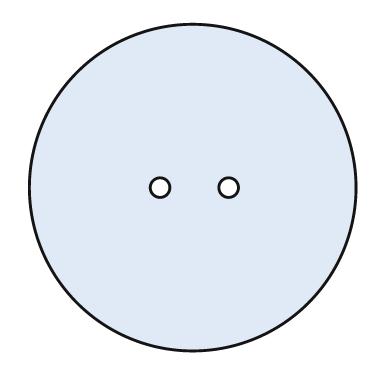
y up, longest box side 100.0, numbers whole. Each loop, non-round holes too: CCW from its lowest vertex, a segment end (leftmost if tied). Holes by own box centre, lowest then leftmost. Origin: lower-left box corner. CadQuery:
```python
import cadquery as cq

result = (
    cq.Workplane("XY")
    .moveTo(50.0, 50.0)
    .circle(50.0)
    .moveTo(40.0, 50.0)
    .circle(3.0)
    .moveTo(61.0, 50.0)
    .circle(3.0)
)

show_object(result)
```